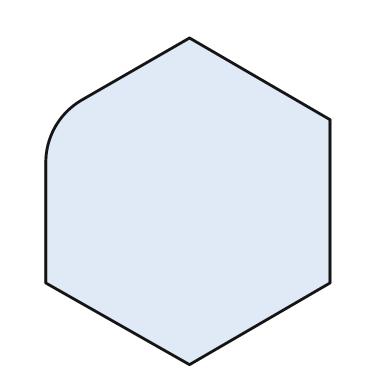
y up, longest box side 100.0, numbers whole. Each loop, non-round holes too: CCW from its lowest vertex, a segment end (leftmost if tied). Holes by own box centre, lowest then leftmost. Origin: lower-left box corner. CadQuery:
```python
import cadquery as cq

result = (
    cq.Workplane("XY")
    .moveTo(44.0, 0.0)
    .lineTo(87.0, 25.0)
    .lineTo(87.0, 75.0)
    .lineTo(44.0, 100.0)
    .lineTo(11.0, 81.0)
    .threePointArc((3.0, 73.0), (0.0, 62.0))
    .lineTo(0.0, 25.0)
    .close()
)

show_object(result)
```